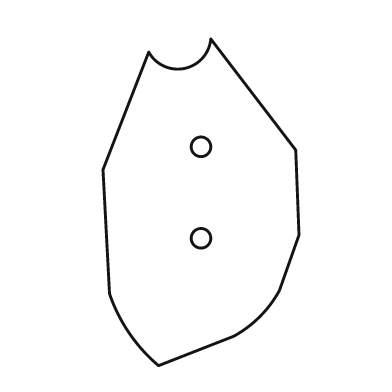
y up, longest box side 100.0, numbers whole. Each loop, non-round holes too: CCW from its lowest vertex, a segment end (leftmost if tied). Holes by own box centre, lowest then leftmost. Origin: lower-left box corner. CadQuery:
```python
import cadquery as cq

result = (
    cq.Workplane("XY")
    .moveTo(17.0, 0.0)
    .lineTo(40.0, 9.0)
    .threePointArc((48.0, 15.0), (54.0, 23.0))
    .lineTo(60.0, 40.0)
    .lineTo(59.0, 66.0)
    .lineTo(33.0, 100.0)
    .threePointArc((25.0, 91.0), (14.0, 96.0))
    .lineTo(0.0, 60.0)
    .lineTo(2.0, 22.0)
    .threePointArc((8.0, 10.0), (17.0, 0.0))
    .close()
    .moveTo(30.0, 39.0)
    .circle(3.0)
    .moveTo(30.0, 67.0)
    .circle(3.0)
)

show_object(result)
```